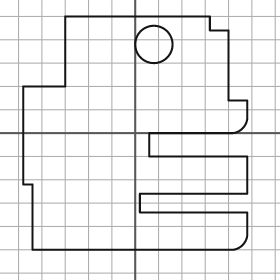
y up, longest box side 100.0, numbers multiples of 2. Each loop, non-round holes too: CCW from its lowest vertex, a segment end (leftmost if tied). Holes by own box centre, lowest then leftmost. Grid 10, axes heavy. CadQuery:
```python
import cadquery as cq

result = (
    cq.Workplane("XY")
    .moveTo(-44.0, -50.0)
    .lineTo(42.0, -50.0)
    .threePointArc((46.0, -48.0), (48.0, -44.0))
    .lineTo(48.0, -34.0)
    .lineTo(2.0, -34.0)
    .lineTo(2.0, -26.0)
    .lineTo(48.0, -26.0)
    .lineTo(48.0, -10.0)
    .lineTo(6.0, -10.0)
    .lineTo(6.0, 0.0)
    .lineTo(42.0, 0.0)
    .threePointArc((46.0, 2.0), (48.0, 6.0))
    .lineTo(48.0, 14.0)
    .lineTo(40.0, 14.0)
    .lineTo(40.0, 44.0)
    .lineTo(32.0, 44.0)
    .lineTo(32.0, 50.0)
    .lineTo(-30.0, 50.0)
    .lineTo(-30.0, 20.0)
    .lineTo(-48.0, 20.0)
    .lineTo(-48.0, -22.0)
    .lineTo(-44.0, -22.0)
    .close()
    .moveTo(8.0, 38.0)
    .circle(8.0)
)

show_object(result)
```